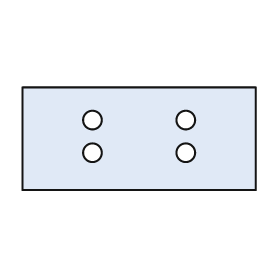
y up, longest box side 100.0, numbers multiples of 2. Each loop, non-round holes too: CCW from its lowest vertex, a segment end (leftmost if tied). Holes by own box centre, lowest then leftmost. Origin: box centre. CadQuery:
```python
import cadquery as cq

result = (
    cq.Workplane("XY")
    .moveTo(-50.0, -22.0)
    .lineTo(50.0, -22.0)
    .lineTo(50.0, 22.0)
    .lineTo(-50.0, 22.0)
    .close()
    .moveTo(-20.0, -6.0)
    .circle(4.0)
    .moveTo(20.0, -6.0)
    .circle(4.0)
    .moveTo(-20.0, 8.0)
    .circle(4.0)
    .moveTo(20.0, 8.0)
    .circle(4.0)
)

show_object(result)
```